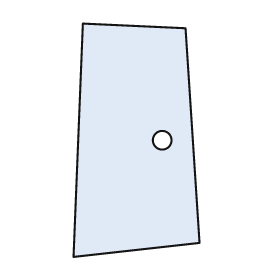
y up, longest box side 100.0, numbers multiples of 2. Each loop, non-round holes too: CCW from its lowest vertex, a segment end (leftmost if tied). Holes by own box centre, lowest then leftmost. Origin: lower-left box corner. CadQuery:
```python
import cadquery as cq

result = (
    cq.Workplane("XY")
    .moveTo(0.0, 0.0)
    .lineTo(54.0, 6.0)
    .lineTo(48.0, 98.0)
    .lineTo(4.0, 100.0)
    .close()
    .moveTo(38.0, 50.0)
    .circle(4.0)
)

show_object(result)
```